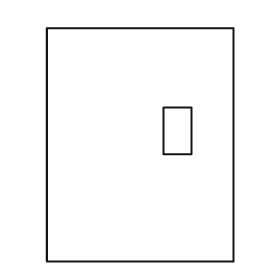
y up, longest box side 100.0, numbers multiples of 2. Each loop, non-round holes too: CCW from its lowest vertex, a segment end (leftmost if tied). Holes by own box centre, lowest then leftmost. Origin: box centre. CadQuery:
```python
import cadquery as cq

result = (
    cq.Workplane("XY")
    .moveTo(-40.0, -50.0)
    .lineTo(40.0, -50.0)
    .lineTo(40.0, 50.0)
    .lineTo(-40.0, 50.0)
    .close()
    .moveTo(10.0, -4.0)
    .lineTo(22.0, -4.0)
    .lineTo(22.0, 16.0)
    .lineTo(10.0, 16.0)
    .close()
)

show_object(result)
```